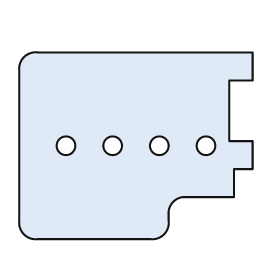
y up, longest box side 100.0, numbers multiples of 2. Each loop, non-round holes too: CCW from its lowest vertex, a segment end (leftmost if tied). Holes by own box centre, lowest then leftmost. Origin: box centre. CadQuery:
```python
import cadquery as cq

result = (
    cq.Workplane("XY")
    .moveTo(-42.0, -40.0)
    .lineTo(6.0, -40.0)
    .threePointArc((12.0, -38.0), (14.0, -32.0))
    .lineTo(14.0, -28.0)
    .threePointArc((16.0, -24.0), (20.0, -22.0))
    .lineTo(42.0, -22.0)
    .lineTo(42.0, -10.0)
    .lineTo(50.0, -10.0)
    .lineTo(50.0, 2.0)
    .lineTo(40.0, 2.0)
    .lineTo(40.0, 28.0)
    .lineTo(50.0, 28.0)
    .lineTo(50.0, 40.0)
    .lineTo(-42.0, 40.0)
    .threePointArc((-48.0, 38.0), (-50.0, 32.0))
    .lineTo(-50.0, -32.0)
    .threePointArc((-48.0, -38.0), (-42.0, -40.0))
    .close()
    .moveTo(-30.0, 0.0)
    .circle(4.0)
    .moveTo(-10.0, 0.0)
    .circle(4.0)
    .moveTo(10.0, 0.0)
    .circle(4.0)
    .moveTo(30.0, 0.0)
    .circle(4.0)
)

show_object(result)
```